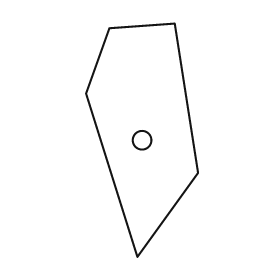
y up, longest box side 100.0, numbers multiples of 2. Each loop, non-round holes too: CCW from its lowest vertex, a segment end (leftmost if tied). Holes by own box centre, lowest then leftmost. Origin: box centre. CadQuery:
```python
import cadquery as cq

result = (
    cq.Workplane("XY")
    .moveTo(-2.0, -50.0)
    .lineTo(24.0, -14.0)
    .lineTo(14.0, 50.0)
    .lineTo(-14.0, 48.0)
    .lineTo(-24.0, 20.0)
    .close()
    .moveTo(0.0, 0.0)
    .circle(4.0)
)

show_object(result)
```